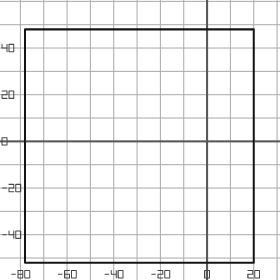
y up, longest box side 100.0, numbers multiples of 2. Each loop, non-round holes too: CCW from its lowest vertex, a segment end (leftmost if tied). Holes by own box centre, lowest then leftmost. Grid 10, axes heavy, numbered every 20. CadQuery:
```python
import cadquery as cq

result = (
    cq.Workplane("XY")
    .moveTo(-78.0, -52.0)
    .lineTo(20.0, -52.0)
    .lineTo(20.0, 48.0)
    .lineTo(-78.0, 48.0)
    .close()
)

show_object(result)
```